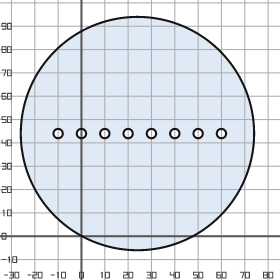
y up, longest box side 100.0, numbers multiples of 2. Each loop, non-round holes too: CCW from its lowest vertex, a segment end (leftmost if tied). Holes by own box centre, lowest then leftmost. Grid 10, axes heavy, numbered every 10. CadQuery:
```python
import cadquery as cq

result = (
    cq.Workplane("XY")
    .moveTo(24.0, 44.0)
    .circle(50.0)
    .moveTo(-10.0, 44.0)
    .circle(2.0)
    .moveTo(0.0, 44.0)
    .circle(2.0)
    .moveTo(10.0, 44.0)
    .circle(2.0)
    .moveTo(20.0, 44.0)
    .circle(2.0)
    .moveTo(30.0, 44.0)
    .circle(2.0)
    .moveTo(40.0, 44.0)
    .circle(2.0)
    .moveTo(50.0, 44.0)
    .circle(2.0)
    .moveTo(60.0, 44.0)
    .circle(2.0)
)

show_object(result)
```